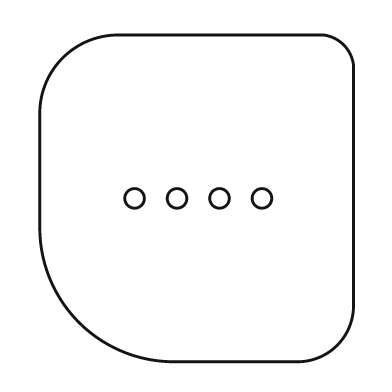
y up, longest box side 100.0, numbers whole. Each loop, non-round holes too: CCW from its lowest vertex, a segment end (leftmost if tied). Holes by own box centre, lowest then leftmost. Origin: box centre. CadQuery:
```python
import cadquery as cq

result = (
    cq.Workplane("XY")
    .moveTo(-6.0, -50.0)
    .lineTo(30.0, -50.0)
    .threePointArc((43.0, -45.0), (48.0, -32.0))
    .lineTo(48.0, 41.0)
    .threePointArc((45.0, 47.0), (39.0, 50.0))
    .lineTo(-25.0, 50.0)
    .threePointArc((-41.0, 43.0), (-48.0, 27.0))
    .lineTo(-48.0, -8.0)
    .threePointArc((-36.0, -38.0), (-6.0, -50.0))
    .close()
    .moveTo(-19.0, 0.0)
    .circle(3.0)
    .moveTo(-6.0, 0.0)
    .circle(3.0)
    .moveTo(7.0, 0.0)
    .circle(3.0)
    .moveTo(20.0, 0.0)
    .circle(3.0)
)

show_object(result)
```